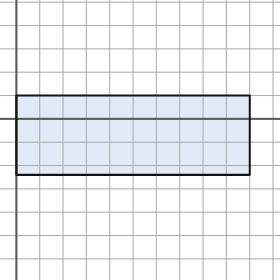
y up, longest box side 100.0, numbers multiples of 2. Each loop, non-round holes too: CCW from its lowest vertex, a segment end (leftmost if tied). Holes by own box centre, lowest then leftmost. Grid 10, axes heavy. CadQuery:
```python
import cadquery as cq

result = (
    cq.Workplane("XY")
    .moveTo(0.0, -24.0)
    .lineTo(100.0, -24.0)
    .lineTo(100.0, 10.0)
    .lineTo(0.0, 10.0)
    .close()
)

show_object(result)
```